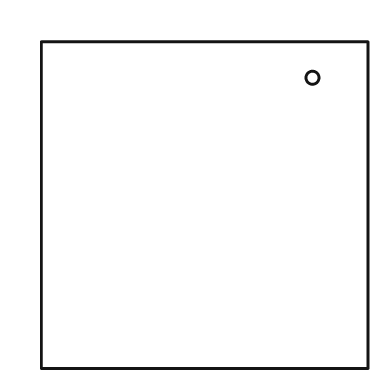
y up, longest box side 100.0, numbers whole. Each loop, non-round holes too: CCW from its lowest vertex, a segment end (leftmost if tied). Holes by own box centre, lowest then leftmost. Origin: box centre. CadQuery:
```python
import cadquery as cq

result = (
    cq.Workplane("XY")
    .moveTo(-50.0, -50.0)
    .lineTo(50.0, -50.0)
    .lineTo(50.0, 50.0)
    .lineTo(-50.0, 50.0)
    .close()
    .moveTo(33.0, 39.0)
    .circle(2.0)
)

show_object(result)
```